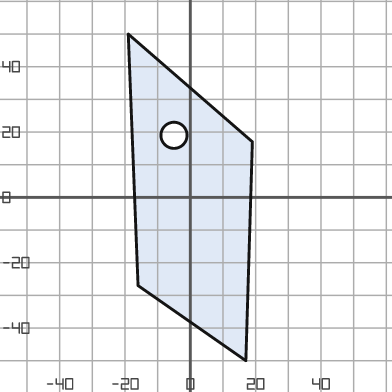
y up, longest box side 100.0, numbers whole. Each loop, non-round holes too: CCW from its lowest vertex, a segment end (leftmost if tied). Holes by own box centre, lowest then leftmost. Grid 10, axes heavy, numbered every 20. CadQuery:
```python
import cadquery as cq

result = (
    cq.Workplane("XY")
    .moveTo(17.0, -50.0)
    .lineTo(19.0, 17.0)
    .lineTo(-19.0, 50.0)
    .lineTo(-16.0, -27.0)
    .close()
    .moveTo(-5.0, 19.0)
    .circle(4.0)
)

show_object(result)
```